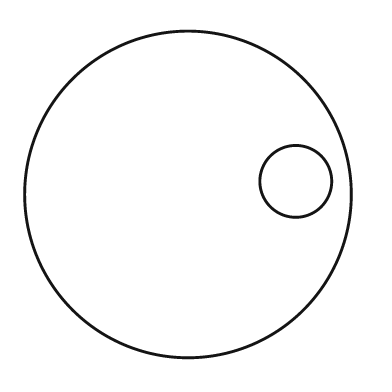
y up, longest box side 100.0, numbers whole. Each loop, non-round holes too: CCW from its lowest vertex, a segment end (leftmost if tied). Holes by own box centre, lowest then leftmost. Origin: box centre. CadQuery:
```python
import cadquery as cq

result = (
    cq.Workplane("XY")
    .moveTo(0.0, 0.0)
    .circle(50.0)
    .moveTo(33.0, 4.0)
    .circle(11.0)
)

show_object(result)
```